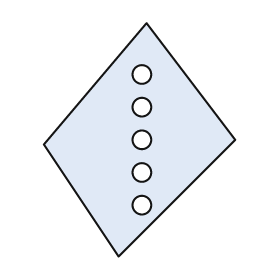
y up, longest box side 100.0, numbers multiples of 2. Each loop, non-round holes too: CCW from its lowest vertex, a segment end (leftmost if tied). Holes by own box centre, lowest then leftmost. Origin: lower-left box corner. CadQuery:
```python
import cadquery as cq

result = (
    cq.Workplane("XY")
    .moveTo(32.0, 0.0)
    .lineTo(82.0, 50.0)
    .lineTo(44.0, 100.0)
    .lineTo(0.0, 48.0)
    .close()
    .moveTo(42.0, 22.0)
    .circle(4.0)
    .moveTo(42.0, 36.0)
    .circle(4.0)
    .moveTo(42.0, 50.0)
    .circle(4.0)
    .moveTo(42.0, 64.0)
    .circle(4.0)
    .moveTo(42.0, 78.0)
    .circle(4.0)
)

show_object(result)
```